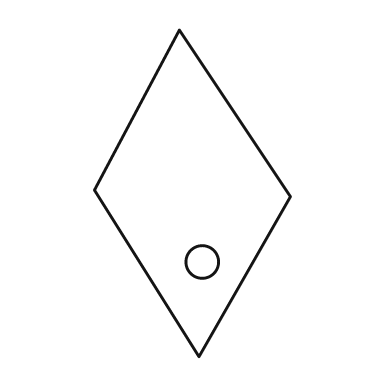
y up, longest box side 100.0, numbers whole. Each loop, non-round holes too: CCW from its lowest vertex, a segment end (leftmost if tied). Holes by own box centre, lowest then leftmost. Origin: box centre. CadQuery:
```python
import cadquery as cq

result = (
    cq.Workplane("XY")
    .moveTo(2.0, -50.0)
    .lineTo(30.0, -1.0)
    .lineTo(-4.0, 50.0)
    .lineTo(-30.0, 1.0)
    .close()
    .moveTo(3.0, -21.0)
    .circle(5.0)
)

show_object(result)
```